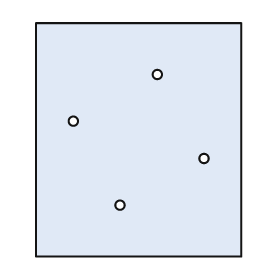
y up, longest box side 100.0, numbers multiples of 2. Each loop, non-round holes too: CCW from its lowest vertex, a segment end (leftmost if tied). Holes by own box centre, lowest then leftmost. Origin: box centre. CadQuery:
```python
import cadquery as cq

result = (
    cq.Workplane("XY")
    .moveTo(-44.0, -50.0)
    .lineTo(44.0, -50.0)
    .lineTo(44.0, 50.0)
    .lineTo(-44.0, 50.0)
    .close()
    .moveTo(-8.0, -28.0)
    .circle(2.0)
    .moveTo(28.0, -8.0)
    .circle(2.0)
    .moveTo(-28.0, 8.0)
    .circle(2.0)
    .moveTo(8.0, 28.0)
    .circle(2.0)
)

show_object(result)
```